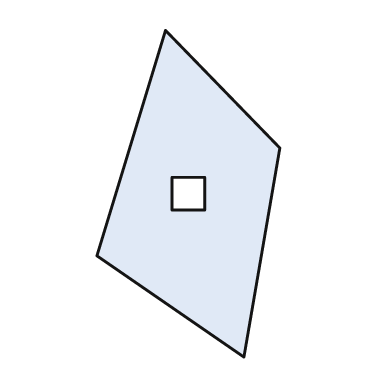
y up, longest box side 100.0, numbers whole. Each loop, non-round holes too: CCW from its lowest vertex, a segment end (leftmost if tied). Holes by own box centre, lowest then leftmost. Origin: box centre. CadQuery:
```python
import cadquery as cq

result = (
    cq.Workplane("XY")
    .moveTo(17.0, -50.0)
    .lineTo(28.0, 14.0)
    .lineTo(-7.0, 50.0)
    .lineTo(-28.0, -19.0)
    .close()
    .moveTo(-5.0, -5.0)
    .lineTo(5.0, -5.0)
    .lineTo(5.0, 5.0)
    .lineTo(-5.0, 5.0)
    .close()
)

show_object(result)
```